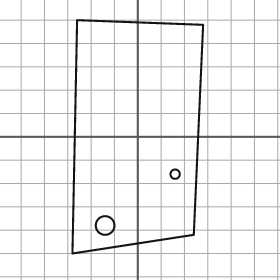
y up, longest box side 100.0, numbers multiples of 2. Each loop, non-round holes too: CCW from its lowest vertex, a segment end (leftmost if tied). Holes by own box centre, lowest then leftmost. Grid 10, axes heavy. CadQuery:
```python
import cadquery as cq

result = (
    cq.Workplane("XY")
    .moveTo(-28.0, -50.0)
    .lineTo(24.0, -42.0)
    .lineTo(28.0, 48.0)
    .lineTo(-26.0, 50.0)
    .close()
    .moveTo(-14.0, -38.0)
    .circle(4.0)
    .moveTo(16.0, -16.0)
    .circle(2.0)
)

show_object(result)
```